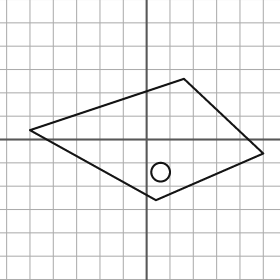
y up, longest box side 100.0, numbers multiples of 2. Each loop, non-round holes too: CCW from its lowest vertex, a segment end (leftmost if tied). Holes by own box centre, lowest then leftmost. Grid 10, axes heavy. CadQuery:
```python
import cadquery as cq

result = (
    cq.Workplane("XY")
    .moveTo(4.0, -26.0)
    .lineTo(50.0, -6.0)
    .lineTo(16.0, 26.0)
    .lineTo(-50.0, 4.0)
    .close()
    .moveTo(6.0, -14.0)
    .circle(4.0)
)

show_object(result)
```